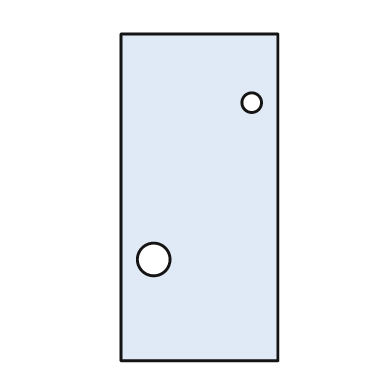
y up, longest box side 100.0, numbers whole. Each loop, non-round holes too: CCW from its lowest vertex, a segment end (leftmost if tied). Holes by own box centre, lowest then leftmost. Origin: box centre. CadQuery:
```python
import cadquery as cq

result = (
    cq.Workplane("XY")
    .moveTo(-24.0, -50.0)
    .lineTo(24.0, -50.0)
    .lineTo(24.0, 50.0)
    .lineTo(-24.0, 50.0)
    .close()
    .moveTo(-14.0, -19.0)
    .circle(5.0)
    .moveTo(16.0, 29.0)
    .circle(3.0)
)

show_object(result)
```